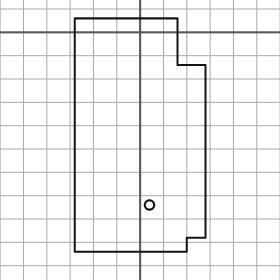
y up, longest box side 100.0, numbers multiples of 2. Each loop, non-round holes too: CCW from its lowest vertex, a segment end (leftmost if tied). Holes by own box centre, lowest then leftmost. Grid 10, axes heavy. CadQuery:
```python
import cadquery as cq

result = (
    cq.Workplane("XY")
    .moveTo(-28.0, -94.0)
    .lineTo(20.0, -94.0)
    .lineTo(20.0, -88.0)
    .lineTo(28.0, -88.0)
    .lineTo(28.0, -14.0)
    .lineTo(16.0, -14.0)
    .lineTo(16.0, 6.0)
    .lineTo(-28.0, 6.0)
    .close()
    .moveTo(4.0, -74.0)
    .circle(2.0)
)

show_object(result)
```